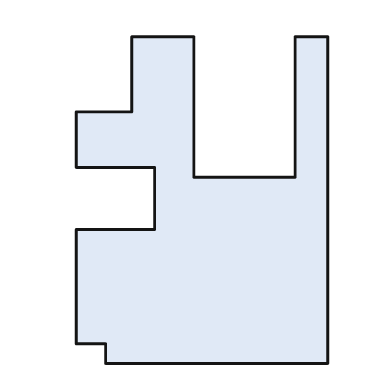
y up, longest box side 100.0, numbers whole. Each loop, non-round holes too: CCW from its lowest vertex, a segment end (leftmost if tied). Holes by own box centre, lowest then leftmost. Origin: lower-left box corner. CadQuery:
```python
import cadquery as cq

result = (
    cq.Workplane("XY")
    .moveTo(9.0, 0.0)
    .lineTo(77.0, 0.0)
    .lineTo(77.0, 100.0)
    .lineTo(67.0, 100.0)
    .lineTo(67.0, 57.0)
    .lineTo(36.0, 57.0)
    .lineTo(36.0, 100.0)
    .lineTo(17.0, 100.0)
    .lineTo(17.0, 77.0)
    .lineTo(0.0, 77.0)
    .lineTo(0.0, 60.0)
    .lineTo(24.0, 60.0)
    .lineTo(24.0, 41.0)
    .lineTo(0.0, 41.0)
    .lineTo(0.0, 6.0)
    .lineTo(9.0, 6.0)
    .close()
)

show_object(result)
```